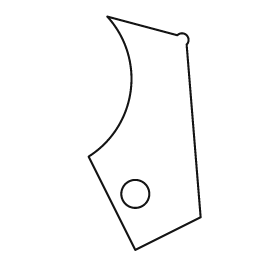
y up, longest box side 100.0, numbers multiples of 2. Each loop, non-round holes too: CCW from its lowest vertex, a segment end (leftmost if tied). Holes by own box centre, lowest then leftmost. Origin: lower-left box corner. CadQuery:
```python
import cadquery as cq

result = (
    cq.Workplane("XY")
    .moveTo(20.0, 0.0)
    .lineTo(48.0, 14.0)
    .lineTo(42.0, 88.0)
    .threePointArc((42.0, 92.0), (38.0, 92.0))
    .lineTo(8.0, 100.0)
    .threePointArc((18.0, 68.0), (0.0, 40.0))
    .close()
    .moveTo(20.0, 24.0)
    .circle(6.0)
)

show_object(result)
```